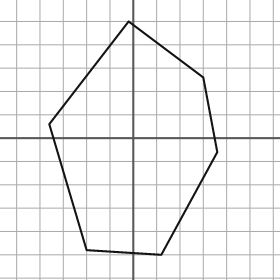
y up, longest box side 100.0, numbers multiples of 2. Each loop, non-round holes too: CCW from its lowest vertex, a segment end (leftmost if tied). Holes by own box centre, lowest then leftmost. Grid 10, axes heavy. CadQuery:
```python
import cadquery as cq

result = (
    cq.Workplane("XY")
    .moveTo(12.0, -50.0)
    .lineTo(36.0, -6.0)
    .lineTo(30.0, 26.0)
    .lineTo(-2.0, 50.0)
    .lineTo(-36.0, 6.0)
    .lineTo(-20.0, -48.0)
    .close()
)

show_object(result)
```